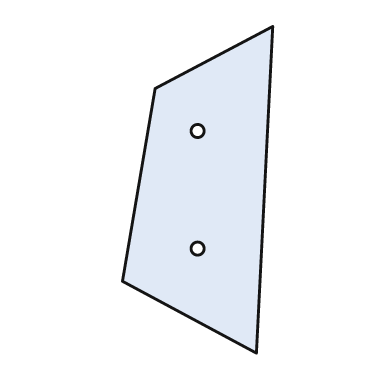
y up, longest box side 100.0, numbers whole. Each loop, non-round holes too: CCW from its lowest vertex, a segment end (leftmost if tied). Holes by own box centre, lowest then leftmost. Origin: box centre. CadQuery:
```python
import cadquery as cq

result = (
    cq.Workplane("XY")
    .moveTo(18.0, -50.0)
    .lineTo(23.0, 50.0)
    .lineTo(-13.0, 31.0)
    .lineTo(-23.0, -28.0)
    .close()
    .moveTo(0.0, -18.0)
    .circle(2.0)
    .moveTo(0.0, 18.0)
    .circle(2.0)
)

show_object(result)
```